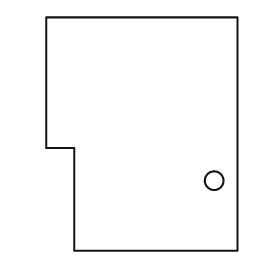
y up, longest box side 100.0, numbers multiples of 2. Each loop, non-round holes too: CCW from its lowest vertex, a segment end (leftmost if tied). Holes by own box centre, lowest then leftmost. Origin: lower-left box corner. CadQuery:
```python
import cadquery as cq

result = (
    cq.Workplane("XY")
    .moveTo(12.0, 0.0)
    .lineTo(82.0, 0.0)
    .lineTo(82.0, 100.0)
    .lineTo(0.0, 100.0)
    .lineTo(0.0, 44.0)
    .lineTo(12.0, 44.0)
    .close()
    .moveTo(72.0, 30.0)
    .circle(4.0)
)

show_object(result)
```